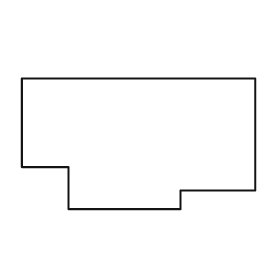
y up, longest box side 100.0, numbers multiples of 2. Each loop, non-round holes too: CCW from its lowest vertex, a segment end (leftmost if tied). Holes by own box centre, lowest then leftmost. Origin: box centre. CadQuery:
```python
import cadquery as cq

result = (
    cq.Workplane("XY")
    .moveTo(-30.0, -28.0)
    .lineTo(18.0, -28.0)
    .lineTo(18.0, -20.0)
    .lineTo(50.0, -20.0)
    .lineTo(50.0, 28.0)
    .lineTo(-50.0, 28.0)
    .lineTo(-50.0, -10.0)
    .lineTo(-30.0, -10.0)
    .close()
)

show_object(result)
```